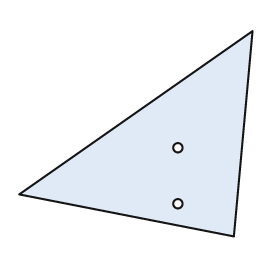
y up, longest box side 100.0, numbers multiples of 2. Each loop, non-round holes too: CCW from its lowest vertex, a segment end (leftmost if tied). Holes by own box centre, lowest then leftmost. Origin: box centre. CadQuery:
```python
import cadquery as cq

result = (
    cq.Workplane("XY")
    .moveTo(42.0, -44.0)
    .lineTo(50.0, 44.0)
    .lineTo(-50.0, -26.0)
    .close()
    .moveTo(18.0, -30.0)
    .circle(2.0)
    .moveTo(18.0, -6.0)
    .circle(2.0)
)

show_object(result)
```